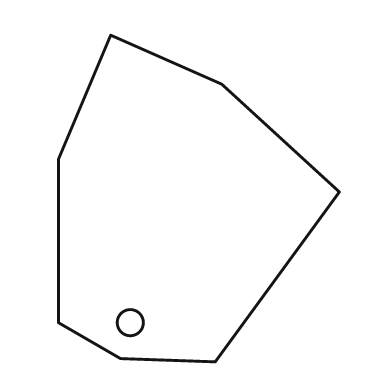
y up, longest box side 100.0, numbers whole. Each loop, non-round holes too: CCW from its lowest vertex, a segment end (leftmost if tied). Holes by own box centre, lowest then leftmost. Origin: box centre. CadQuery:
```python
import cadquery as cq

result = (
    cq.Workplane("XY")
    .moveTo(5.0, -50.0)
    .lineTo(43.0, 2.0)
    .lineTo(7.0, 35.0)
    .lineTo(-27.0, 50.0)
    .lineTo(-43.0, 12.0)
    .lineTo(-43.0, -38.0)
    .lineTo(-24.0, -49.0)
    .close()
    .moveTo(-21.0, -38.0)
    .circle(4.0)
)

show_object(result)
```